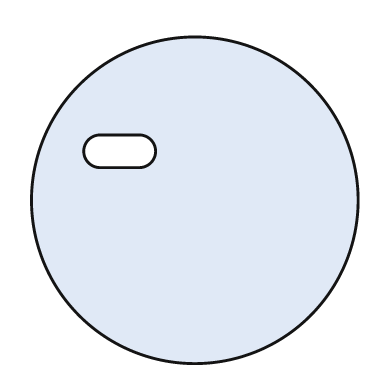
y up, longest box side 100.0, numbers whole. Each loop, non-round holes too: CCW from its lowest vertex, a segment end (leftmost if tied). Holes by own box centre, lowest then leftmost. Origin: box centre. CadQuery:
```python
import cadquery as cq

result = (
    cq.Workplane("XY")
    .moveTo(0.0, 0.0)
    .circle(50.0)
    .moveTo(-29.0, 10.0)
    .lineTo(-17.0, 10.0)
    .threePointArc((-12.0, 15.0), (-17.0, 20.0))
    .lineTo(-29.0, 20.0)
    .threePointArc((-34.0, 15.0), (-29.0, 10.0))
    .close()
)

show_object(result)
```